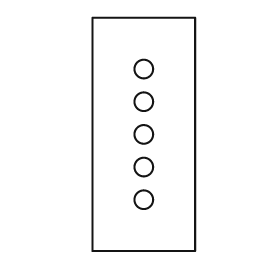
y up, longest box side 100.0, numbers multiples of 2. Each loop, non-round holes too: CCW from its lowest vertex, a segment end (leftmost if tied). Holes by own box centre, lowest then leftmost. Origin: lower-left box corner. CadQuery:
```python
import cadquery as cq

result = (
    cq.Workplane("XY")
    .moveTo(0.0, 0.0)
    .lineTo(44.0, 0.0)
    .lineTo(44.0, 100.0)
    .lineTo(0.0, 100.0)
    .close()
    .moveTo(22.0, 22.0)
    .circle(4.0)
    .moveTo(22.0, 36.0)
    .circle(4.0)
    .moveTo(22.0, 50.0)
    .circle(4.0)
    .moveTo(22.0, 64.0)
    .circle(4.0)
    .moveTo(22.0, 78.0)
    .circle(4.0)
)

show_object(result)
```